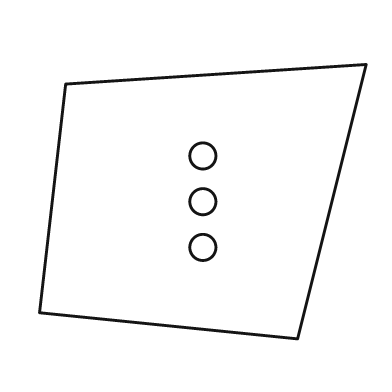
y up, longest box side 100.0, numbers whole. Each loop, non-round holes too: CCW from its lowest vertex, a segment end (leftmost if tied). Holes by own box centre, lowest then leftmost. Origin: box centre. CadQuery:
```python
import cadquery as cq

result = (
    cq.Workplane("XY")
    .moveTo(29.0, -42.0)
    .lineTo(50.0, 42.0)
    .lineTo(-42.0, 36.0)
    .lineTo(-50.0, -34.0)
    .close()
    .moveTo(0.0, -14.0)
    .circle(4.0)
    .moveTo(0.0, 0.0)
    .circle(4.0)
    .moveTo(0.0, 14.0)
    .circle(4.0)
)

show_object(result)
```